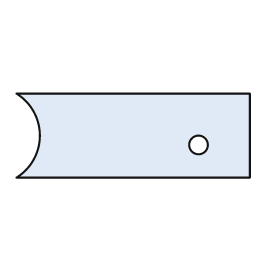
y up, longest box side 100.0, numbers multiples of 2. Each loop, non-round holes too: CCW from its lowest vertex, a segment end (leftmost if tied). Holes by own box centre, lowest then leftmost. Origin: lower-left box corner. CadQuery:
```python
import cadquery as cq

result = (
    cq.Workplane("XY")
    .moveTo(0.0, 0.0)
    .lineTo(100.0, 0.0)
    .lineTo(100.0, 36.0)
    .lineTo(0.0, 36.0)
    .threePointArc((10.0, 18.0), (0.0, 0.0))
    .close()
    .moveTo(78.0, 14.0)
    .circle(4.0)
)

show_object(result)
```